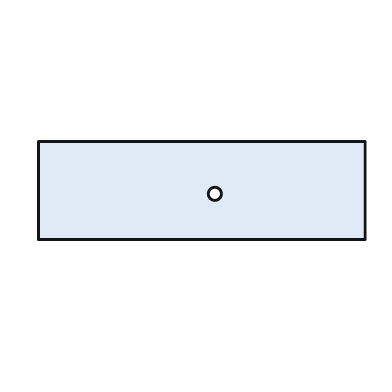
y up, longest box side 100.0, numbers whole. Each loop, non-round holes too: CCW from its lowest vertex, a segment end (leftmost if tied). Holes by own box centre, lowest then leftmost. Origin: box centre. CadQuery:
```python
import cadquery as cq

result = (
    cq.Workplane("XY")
    .moveTo(-50.0, -15.0)
    .lineTo(50.0, -15.0)
    .lineTo(50.0, 15.0)
    .lineTo(-50.0, 15.0)
    .close()
    .moveTo(4.0, -1.0)
    .circle(2.0)
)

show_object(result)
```